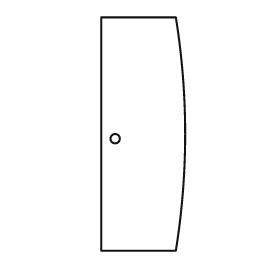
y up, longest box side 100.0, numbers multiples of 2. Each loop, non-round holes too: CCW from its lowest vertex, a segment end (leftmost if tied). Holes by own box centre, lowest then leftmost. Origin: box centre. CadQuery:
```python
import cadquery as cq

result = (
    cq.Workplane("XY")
    .moveTo(-18.0, -50.0)
    .lineTo(14.0, -50.0)
    .threePointArc((18.0, 0.0), (14.0, 50.0))
    .lineTo(-18.0, 50.0)
    .close()
    .moveTo(-12.0, -2.0)
    .circle(2.0)
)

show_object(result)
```